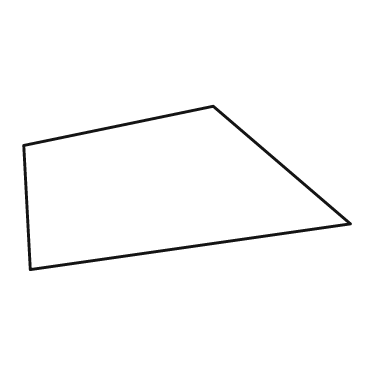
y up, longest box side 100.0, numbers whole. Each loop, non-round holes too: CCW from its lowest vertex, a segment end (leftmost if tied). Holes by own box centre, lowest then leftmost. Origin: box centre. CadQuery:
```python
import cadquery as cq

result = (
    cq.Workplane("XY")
    .moveTo(-48.0, -25.0)
    .lineTo(50.0, -11.0)
    .lineTo(8.0, 25.0)
    .lineTo(-50.0, 13.0)
    .close()
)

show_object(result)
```